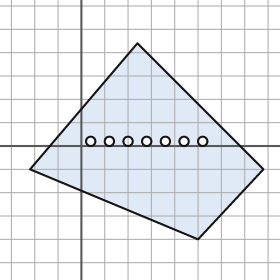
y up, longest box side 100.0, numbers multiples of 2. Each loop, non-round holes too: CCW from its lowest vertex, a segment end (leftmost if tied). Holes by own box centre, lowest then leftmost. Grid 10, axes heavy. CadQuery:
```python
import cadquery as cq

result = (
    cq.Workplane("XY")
    .moveTo(50.0, -40.0)
    .lineTo(78.0, -10.0)
    .lineTo(24.0, 44.0)
    .lineTo(-22.0, -10.0)
    .close()
    .moveTo(4.0, 2.0)
    .circle(2.0)
    .moveTo(12.0, 2.0)
    .circle(2.0)
    .moveTo(20.0, 2.0)
    .circle(2.0)
    .moveTo(28.0, 2.0)
    .circle(2.0)
    .moveTo(36.0, 2.0)
    .circle(2.0)
    .moveTo(44.0, 2.0)
    .circle(2.0)
    .moveTo(52.0, 2.0)
    .circle(2.0)
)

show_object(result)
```